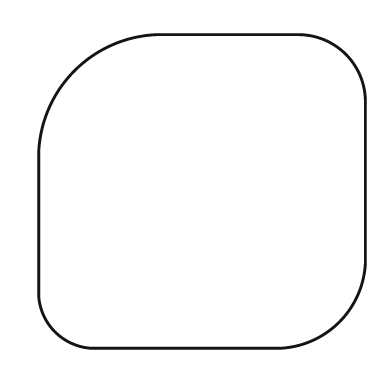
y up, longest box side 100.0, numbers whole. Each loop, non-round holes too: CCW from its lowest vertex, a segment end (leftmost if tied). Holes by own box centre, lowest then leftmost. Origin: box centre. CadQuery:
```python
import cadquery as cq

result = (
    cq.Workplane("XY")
    .moveTo(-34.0, -48.0)
    .lineTo(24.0, -48.0)
    .threePointArc((42.0, -40.0), (50.0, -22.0))
    .lineTo(50.0, 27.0)
    .threePointArc((44.0, 42.0), (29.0, 48.0))
    .lineTo(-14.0, 48.0)
    .threePointArc((-39.0, 37.0), (-50.0, 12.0))
    .lineTo(-50.0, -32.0)
    .threePointArc((-45.0, -43.0), (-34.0, -48.0))
    .close()
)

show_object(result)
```